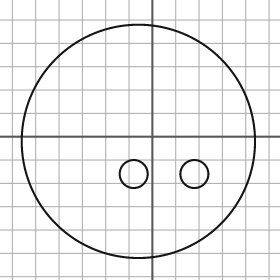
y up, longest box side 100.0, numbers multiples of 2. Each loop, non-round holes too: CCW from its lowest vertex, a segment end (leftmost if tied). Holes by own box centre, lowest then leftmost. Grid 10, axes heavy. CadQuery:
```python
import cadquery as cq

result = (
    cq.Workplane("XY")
    .moveTo(-6.0, -2.0)
    .circle(50.0)
    .moveTo(-8.0, -16.0)
    .circle(6.0)
    .moveTo(18.0, -16.0)
    .circle(6.0)
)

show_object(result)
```